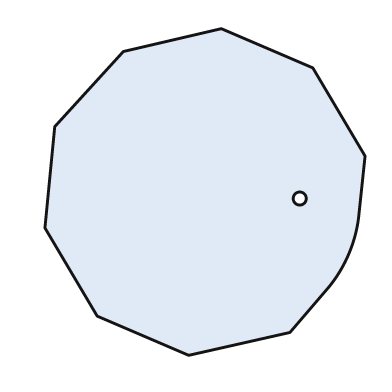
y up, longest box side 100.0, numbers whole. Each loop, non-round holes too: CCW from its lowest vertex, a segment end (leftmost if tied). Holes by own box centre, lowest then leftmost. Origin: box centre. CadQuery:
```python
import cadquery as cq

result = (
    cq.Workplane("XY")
    .moveTo(-5.0, -50.0)
    .lineTo(26.0, -43.0)
    .lineTo(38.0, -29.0)
    .threePointArc((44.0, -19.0), (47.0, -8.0))
    .lineTo(49.0, 11.0)
    .lineTo(33.0, 38.0)
    .lineTo(5.0, 50.0)
    .lineTo(-25.0, 43.0)
    .lineTo(-46.0, 20.0)
    .lineTo(-49.0, -11.0)
    .lineTo(-33.0, -38.0)
    .close()
    .moveTo(29.0, -2.0)
    .circle(2.0)
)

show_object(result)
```